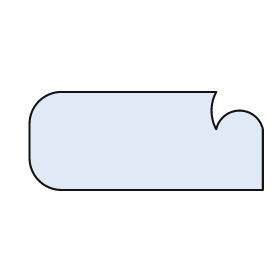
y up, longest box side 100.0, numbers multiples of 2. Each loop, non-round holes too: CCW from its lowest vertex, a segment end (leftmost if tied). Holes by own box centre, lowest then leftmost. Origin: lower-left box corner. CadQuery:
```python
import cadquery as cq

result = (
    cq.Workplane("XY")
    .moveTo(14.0, 0.0)
    .lineTo(100.0, 0.0)
    .lineTo(100.0, 26.0)
    .threePointArc((90.0, 34.0), (80.0, 26.0))
    .threePointArc((78.0, 34.0), (80.0, 42.0))
    .lineTo(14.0, 42.0)
    .threePointArc((4.0, 38.0), (0.0, 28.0))
    .lineTo(0.0, 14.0)
    .threePointArc((4.0, 4.0), (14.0, 0.0))
    .close()
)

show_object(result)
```